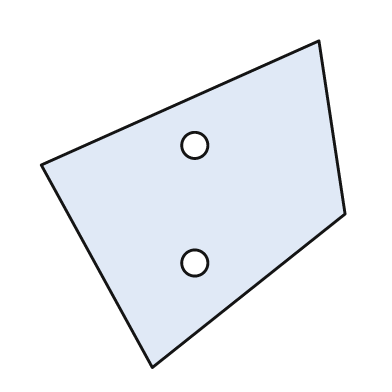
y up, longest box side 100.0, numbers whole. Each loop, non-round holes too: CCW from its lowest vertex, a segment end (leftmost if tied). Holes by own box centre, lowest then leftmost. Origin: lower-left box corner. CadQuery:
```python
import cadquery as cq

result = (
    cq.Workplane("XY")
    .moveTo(34.0, 0.0)
    .lineTo(93.0, 47.0)
    .lineTo(85.0, 100.0)
    .lineTo(0.0, 62.0)
    .close()
    .moveTo(47.0, 32.0)
    .circle(4.0)
    .moveTo(47.0, 68.0)
    .circle(4.0)
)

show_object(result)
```